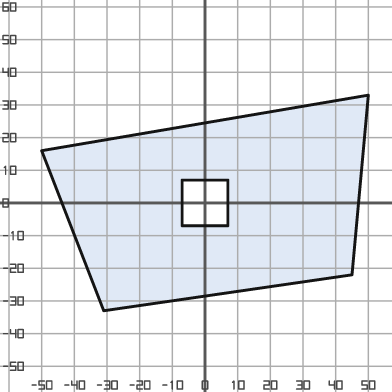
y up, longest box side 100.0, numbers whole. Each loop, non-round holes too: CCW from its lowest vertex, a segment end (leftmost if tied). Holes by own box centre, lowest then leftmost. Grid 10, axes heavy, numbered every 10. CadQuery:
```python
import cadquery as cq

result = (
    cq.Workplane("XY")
    .moveTo(-31.0, -33.0)
    .lineTo(45.0, -22.0)
    .lineTo(50.0, 33.0)
    .lineTo(-50.0, 16.0)
    .close()
    .moveTo(-7.0, -7.0)
    .lineTo(7.0, -7.0)
    .lineTo(7.0, 7.0)
    .lineTo(-7.0, 7.0)
    .close()
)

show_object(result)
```